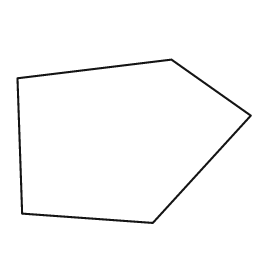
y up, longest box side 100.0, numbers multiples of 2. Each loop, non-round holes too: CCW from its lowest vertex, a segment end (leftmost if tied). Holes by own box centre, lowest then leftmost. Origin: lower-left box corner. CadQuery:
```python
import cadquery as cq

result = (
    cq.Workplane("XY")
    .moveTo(58.0, 0.0)
    .lineTo(100.0, 46.0)
    .lineTo(66.0, 70.0)
    .lineTo(0.0, 62.0)
    .lineTo(2.0, 4.0)
    .close()
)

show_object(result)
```